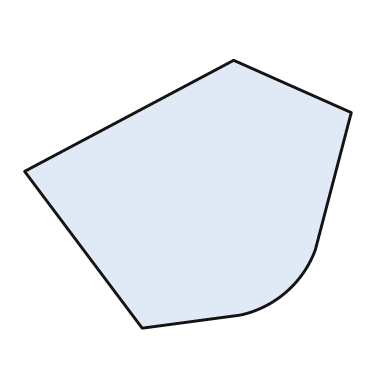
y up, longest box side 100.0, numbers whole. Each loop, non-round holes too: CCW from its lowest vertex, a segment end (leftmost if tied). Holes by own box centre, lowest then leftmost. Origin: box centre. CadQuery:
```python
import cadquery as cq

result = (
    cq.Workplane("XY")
    .moveTo(-14.0, -41.0)
    .lineTo(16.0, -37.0)
    .threePointArc((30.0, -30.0), (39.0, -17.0))
    .lineTo(50.0, 25.0)
    .lineTo(14.0, 41.0)
    .lineTo(-50.0, 7.0)
    .close()
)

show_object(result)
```